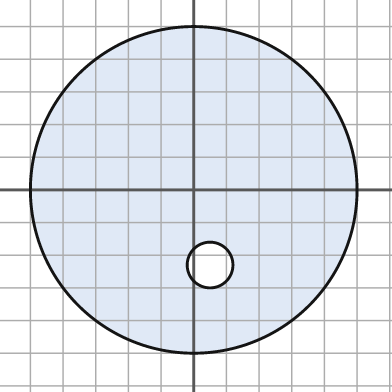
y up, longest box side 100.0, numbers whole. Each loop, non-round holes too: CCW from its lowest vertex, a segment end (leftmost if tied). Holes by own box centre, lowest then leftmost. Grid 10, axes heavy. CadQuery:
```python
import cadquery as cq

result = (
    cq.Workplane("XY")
    .moveTo(0.0, 0.0)
    .circle(50.0)
    .moveTo(5.0, -23.0)
    .circle(7.0)
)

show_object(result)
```